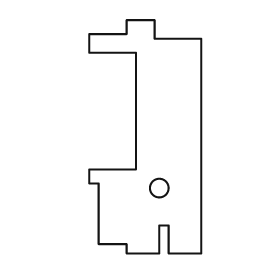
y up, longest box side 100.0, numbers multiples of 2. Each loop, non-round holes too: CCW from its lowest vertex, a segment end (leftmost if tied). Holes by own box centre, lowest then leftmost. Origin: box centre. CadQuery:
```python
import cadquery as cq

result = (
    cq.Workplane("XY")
    .moveTo(-8.0, -50.0)
    .lineTo(6.0, -50.0)
    .lineTo(6.0, -38.0)
    .lineTo(10.0, -38.0)
    .lineTo(10.0, -50.0)
    .lineTo(24.0, -50.0)
    .lineTo(24.0, 42.0)
    .lineTo(4.0, 42.0)
    .lineTo(4.0, 50.0)
    .lineTo(-8.0, 50.0)
    .lineTo(-8.0, 44.0)
    .lineTo(-24.0, 44.0)
    .lineTo(-24.0, 36.0)
    .lineTo(-4.0, 36.0)
    .lineTo(-4.0, -14.0)
    .lineTo(-24.0, -14.0)
    .lineTo(-24.0, -20.0)
    .lineTo(-20.0, -20.0)
    .lineTo(-20.0, -46.0)
    .lineTo(-8.0, -46.0)
    .close()
    .moveTo(6.0, -22.0)
    .circle(4.0)
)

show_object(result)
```